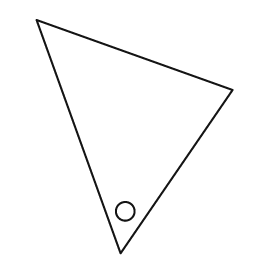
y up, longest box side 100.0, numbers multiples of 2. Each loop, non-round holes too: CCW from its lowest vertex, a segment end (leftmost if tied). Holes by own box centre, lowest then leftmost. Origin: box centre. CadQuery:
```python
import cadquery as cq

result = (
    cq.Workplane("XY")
    .moveTo(-6.0, -50.0)
    .lineTo(42.0, 20.0)
    .lineTo(-42.0, 50.0)
    .close()
    .moveTo(-4.0, -32.0)
    .circle(4.0)
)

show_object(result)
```